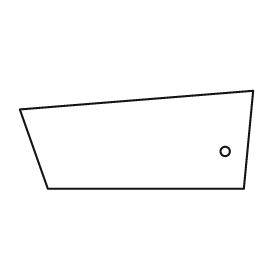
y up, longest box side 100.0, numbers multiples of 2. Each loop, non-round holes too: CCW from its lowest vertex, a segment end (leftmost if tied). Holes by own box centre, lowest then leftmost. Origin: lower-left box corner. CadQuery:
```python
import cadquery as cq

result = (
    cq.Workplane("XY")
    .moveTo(12.0, 0.0)
    .lineTo(96.0, 0.0)
    .lineTo(100.0, 42.0)
    .lineTo(0.0, 34.0)
    .close()
    .moveTo(88.0, 16.0)
    .circle(2.0)
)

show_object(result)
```